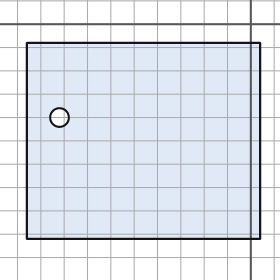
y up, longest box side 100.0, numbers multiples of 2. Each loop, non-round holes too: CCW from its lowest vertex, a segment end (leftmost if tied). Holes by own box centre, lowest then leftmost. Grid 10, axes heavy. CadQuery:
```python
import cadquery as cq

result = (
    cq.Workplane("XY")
    .moveTo(-96.0, -92.0)
    .lineTo(4.0, -92.0)
    .lineTo(4.0, -8.0)
    .lineTo(-96.0, -8.0)
    .close()
    .moveTo(-82.0, -40.0)
    .circle(4.0)
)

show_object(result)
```